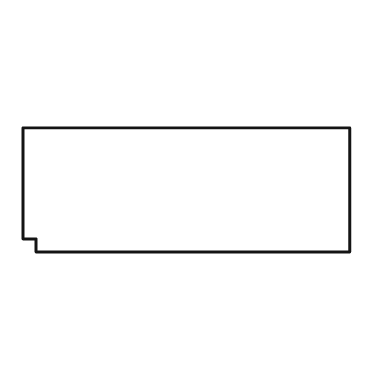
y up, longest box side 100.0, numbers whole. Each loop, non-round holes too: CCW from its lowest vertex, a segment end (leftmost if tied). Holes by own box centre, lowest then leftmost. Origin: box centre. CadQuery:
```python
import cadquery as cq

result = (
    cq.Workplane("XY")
    .moveTo(-46.0, -19.0)
    .lineTo(50.0, -19.0)
    .lineTo(50.0, 19.0)
    .lineTo(-50.0, 19.0)
    .lineTo(-50.0, -15.0)
    .lineTo(-46.0, -15.0)
    .close()
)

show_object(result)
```